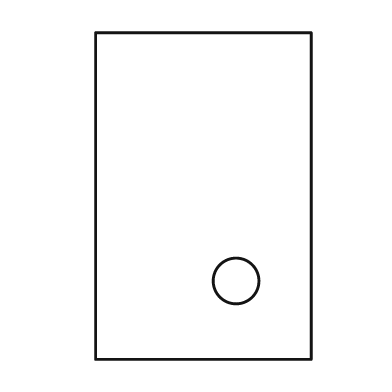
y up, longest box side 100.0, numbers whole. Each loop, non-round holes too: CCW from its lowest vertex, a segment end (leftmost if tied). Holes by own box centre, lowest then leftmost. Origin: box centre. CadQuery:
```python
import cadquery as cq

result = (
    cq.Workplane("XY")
    .moveTo(-33.0, -50.0)
    .lineTo(33.0, -50.0)
    .lineTo(33.0, 50.0)
    .lineTo(-33.0, 50.0)
    .close()
    .moveTo(10.0, -26.0)
    .circle(7.0)
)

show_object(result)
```